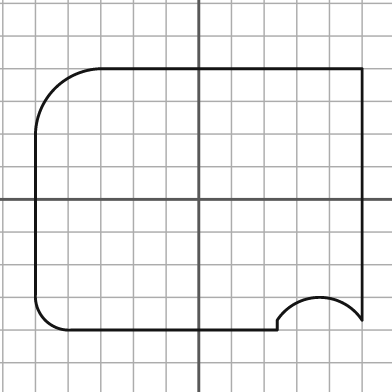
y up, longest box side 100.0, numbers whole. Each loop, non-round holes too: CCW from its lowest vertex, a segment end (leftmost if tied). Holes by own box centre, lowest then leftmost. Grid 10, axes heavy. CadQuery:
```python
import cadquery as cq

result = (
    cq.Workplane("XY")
    .moveTo(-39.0, -40.0)
    .lineTo(24.0, -40.0)
    .lineTo(24.0, -37.0)
    .threePointArc((37.0, -30.0), (50.0, -37.0))
    .lineTo(50.0, 40.0)
    .lineTo(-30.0, 40.0)
    .threePointArc((-44.0, 34.0), (-50.0, 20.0))
    .lineTo(-50.0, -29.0)
    .threePointArc((-47.0, -37.0), (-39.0, -40.0))
    .close()
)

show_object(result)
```